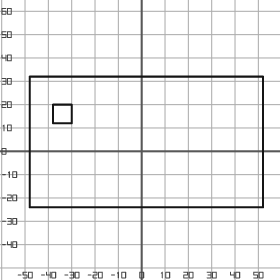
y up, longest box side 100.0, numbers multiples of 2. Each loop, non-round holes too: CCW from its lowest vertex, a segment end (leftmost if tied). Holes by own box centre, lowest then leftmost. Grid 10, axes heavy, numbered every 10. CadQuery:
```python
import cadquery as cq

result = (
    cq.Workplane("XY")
    .moveTo(-48.0, -24.0)
    .lineTo(52.0, -24.0)
    .lineTo(52.0, 32.0)
    .lineTo(-48.0, 32.0)
    .close()
    .moveTo(-38.0, 12.0)
    .lineTo(-30.0, 12.0)
    .lineTo(-30.0, 20.0)
    .lineTo(-38.0, 20.0)
    .close()
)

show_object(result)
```